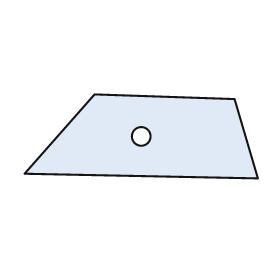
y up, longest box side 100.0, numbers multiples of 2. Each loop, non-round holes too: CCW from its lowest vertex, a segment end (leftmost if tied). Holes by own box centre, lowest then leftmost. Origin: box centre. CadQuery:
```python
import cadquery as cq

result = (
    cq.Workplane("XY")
    .moveTo(50.0, -18.0)
    .lineTo(40.0, 16.0)
    .lineTo(-20.0, 18.0)
    .lineTo(-50.0, -16.0)
    .close()
    .moveTo(0.0, 0.0)
    .circle(4.0)
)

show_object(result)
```